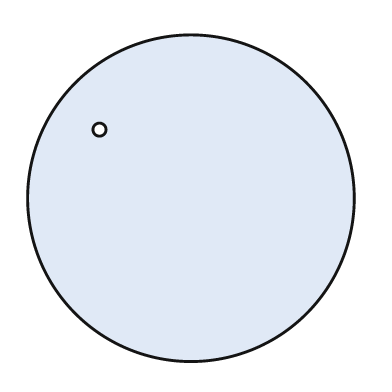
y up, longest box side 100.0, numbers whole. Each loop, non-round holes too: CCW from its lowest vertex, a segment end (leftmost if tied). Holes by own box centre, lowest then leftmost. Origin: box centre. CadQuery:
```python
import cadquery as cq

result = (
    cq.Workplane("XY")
    .moveTo(0.0, 0.0)
    .circle(50.0)
    .moveTo(-28.0, 21.0)
    .circle(2.0)
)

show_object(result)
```